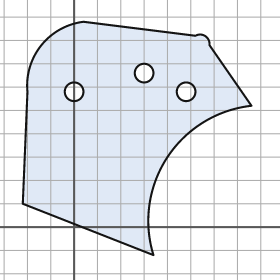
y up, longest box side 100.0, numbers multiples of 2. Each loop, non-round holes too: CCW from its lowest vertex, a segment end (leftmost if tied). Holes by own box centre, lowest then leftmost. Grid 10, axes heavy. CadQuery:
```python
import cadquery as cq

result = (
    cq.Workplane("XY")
    .moveTo(34.0, -12.0)
    .threePointArc((40.0, 30.0), (76.0, 52.0))
    .lineTo(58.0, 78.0)
    .threePointArc((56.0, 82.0), (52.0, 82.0))
    .lineTo(4.0, 88.0)
    .threePointArc((-14.0, 78.0), (-20.0, 58.0))
    .lineTo(-22.0, 10.0)
    .close()
    .moveTo(0.0, 58.0)
    .circle(4.0)
    .moveTo(48.0, 58.0)
    .circle(4.0)
    .moveTo(30.0, 66.0)
    .circle(4.0)
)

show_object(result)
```